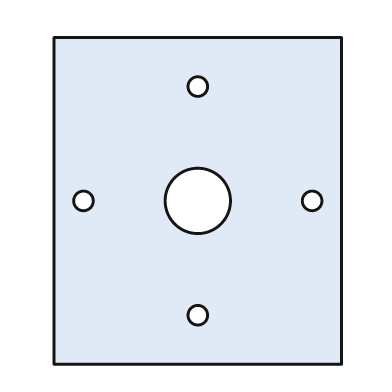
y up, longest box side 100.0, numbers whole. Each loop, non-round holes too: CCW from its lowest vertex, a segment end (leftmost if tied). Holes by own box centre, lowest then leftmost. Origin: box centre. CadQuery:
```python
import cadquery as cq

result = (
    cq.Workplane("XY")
    .moveTo(-44.0, -50.0)
    .lineTo(44.0, -50.0)
    .lineTo(44.0, 50.0)
    .lineTo(-44.0, 50.0)
    .close()
    .moveTo(0.0, -35.0)
    .circle(3.0)
    .moveTo(-35.0, 0.0)
    .circle(3.0)
    .moveTo(0.0, 0.0)
    .circle(10.0)
    .moveTo(35.0, 0.0)
    .circle(3.0)
    .moveTo(0.0, 35.0)
    .circle(3.0)
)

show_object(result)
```